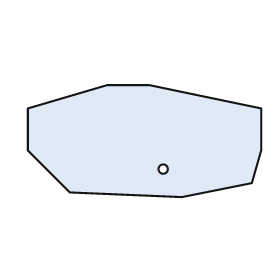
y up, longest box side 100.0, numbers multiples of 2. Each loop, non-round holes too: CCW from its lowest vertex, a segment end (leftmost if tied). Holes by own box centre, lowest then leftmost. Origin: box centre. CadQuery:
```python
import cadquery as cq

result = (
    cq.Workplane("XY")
    .moveTo(16.0, -24.0)
    .lineTo(46.0, -18.0)
    .lineTo(50.0, -4.0)
    .lineTo(50.0, 14.0)
    .lineTo(2.0, 24.0)
    .lineTo(-16.0, 24.0)
    .lineTo(-50.0, 14.0)
    .lineTo(-50.0, -4.0)
    .lineTo(-32.0, -22.0)
    .close()
    .moveTo(8.0, -12.0)
    .circle(2.0)
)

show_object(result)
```